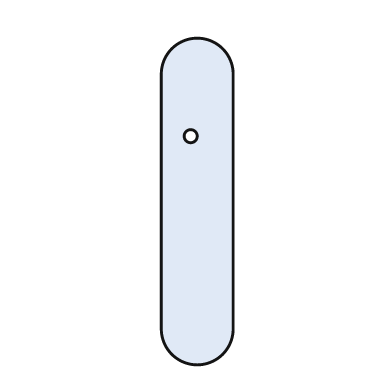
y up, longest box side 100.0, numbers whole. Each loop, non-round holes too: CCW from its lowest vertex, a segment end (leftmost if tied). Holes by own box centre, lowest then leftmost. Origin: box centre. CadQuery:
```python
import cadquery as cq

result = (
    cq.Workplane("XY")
    .moveTo(-11.0, -39.0)
    .threePointArc((0.0, -50.0), (11.0, -39.0))
    .lineTo(11.0, 39.0)
    .threePointArc((0.0, 50.0), (-11.0, 39.0))
    .close()
    .moveTo(-2.0, 20.0)
    .circle(2.0)
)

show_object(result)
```